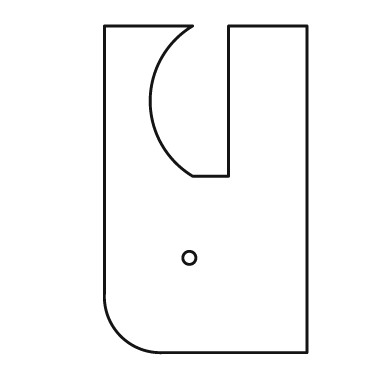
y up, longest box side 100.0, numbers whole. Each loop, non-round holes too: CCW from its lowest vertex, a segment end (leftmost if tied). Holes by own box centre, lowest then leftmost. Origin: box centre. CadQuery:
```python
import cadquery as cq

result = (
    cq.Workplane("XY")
    .moveTo(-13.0, -50.0)
    .lineTo(31.0, -50.0)
    .lineTo(31.0, 50.0)
    .lineTo(7.0, 50.0)
    .lineTo(7.0, 4.0)
    .lineTo(-4.0, 4.0)
    .threePointArc((-17.0, 27.0), (-4.0, 50.0))
    .lineTo(-31.0, 50.0)
    .lineTo(-31.0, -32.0)
    .threePointArc((-26.0, -45.0), (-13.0, -50.0))
    .close()
    .moveTo(-5.0, -21.0)
    .circle(2.0)
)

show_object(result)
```